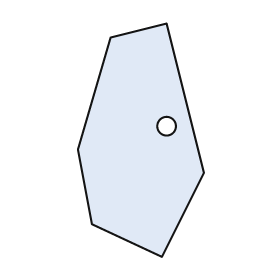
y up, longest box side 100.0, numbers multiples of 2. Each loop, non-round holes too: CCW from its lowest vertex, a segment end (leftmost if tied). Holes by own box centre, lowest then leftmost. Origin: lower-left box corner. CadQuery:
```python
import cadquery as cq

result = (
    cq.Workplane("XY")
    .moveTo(36.0, 0.0)
    .lineTo(54.0, 36.0)
    .lineTo(38.0, 100.0)
    .lineTo(14.0, 94.0)
    .lineTo(0.0, 46.0)
    .lineTo(6.0, 14.0)
    .close()
    .moveTo(38.0, 56.0)
    .circle(4.0)
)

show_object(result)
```